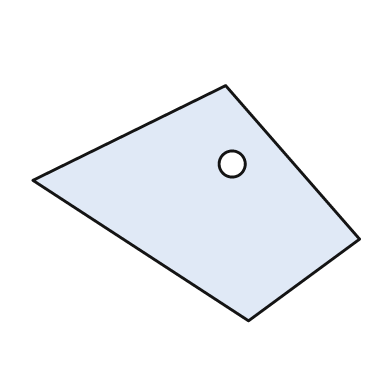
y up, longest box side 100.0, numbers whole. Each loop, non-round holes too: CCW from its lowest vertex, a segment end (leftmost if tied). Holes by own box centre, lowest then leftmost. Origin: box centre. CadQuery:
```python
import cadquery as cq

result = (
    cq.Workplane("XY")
    .moveTo(16.0, -36.0)
    .lineTo(50.0, -11.0)
    .lineTo(9.0, 36.0)
    .lineTo(-50.0, 7.0)
    .close()
    .moveTo(11.0, 12.0)
    .circle(4.0)
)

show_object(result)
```